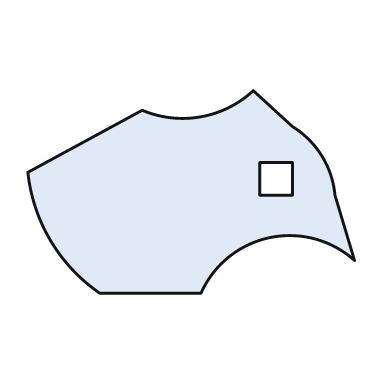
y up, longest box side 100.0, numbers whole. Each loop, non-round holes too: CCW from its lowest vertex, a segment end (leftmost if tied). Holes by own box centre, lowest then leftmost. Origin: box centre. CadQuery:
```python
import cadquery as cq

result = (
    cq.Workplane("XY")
    .moveTo(-28.0, -31.0)
    .lineTo(3.0, -31.0)
    .threePointArc((24.0, -14.0), (50.0, -21.0))
    .lineTo(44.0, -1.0)
    .threePointArc((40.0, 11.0), (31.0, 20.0))
    .lineTo(19.0, 31.0)
    .threePointArc((3.0, 23.0), (-15.0, 25.0))
    .lineTo(-50.0, 6.0)
    .threePointArc((-43.0, -15.0), (-28.0, -31.0))
    .close()
    .moveTo(21.0, -1.0)
    .lineTo(31.0, -1.0)
    .lineTo(31.0, 9.0)
    .lineTo(21.0, 9.0)
    .close()
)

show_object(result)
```